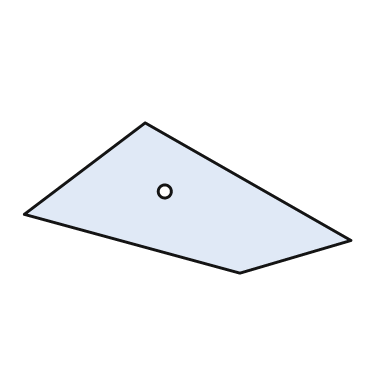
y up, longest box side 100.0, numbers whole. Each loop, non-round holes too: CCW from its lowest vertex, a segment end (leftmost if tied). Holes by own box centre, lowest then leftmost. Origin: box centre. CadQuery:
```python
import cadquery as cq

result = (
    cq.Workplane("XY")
    .moveTo(16.0, -23.0)
    .lineTo(50.0, -13.0)
    .lineTo(-13.0, 23.0)
    .lineTo(-50.0, -5.0)
    .close()
    .moveTo(-7.0, 2.0)
    .circle(2.0)
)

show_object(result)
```